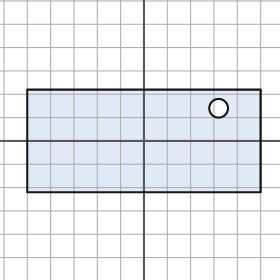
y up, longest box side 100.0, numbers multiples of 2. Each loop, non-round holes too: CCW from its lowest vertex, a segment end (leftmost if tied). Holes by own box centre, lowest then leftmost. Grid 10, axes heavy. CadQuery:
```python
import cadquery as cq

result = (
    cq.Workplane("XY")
    .moveTo(-50.0, -22.0)
    .lineTo(50.0, -22.0)
    .lineTo(50.0, 22.0)
    .lineTo(-50.0, 22.0)
    .close()
    .moveTo(32.0, 14.0)
    .circle(4.0)
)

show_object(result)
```